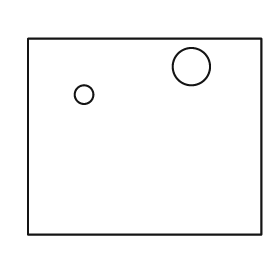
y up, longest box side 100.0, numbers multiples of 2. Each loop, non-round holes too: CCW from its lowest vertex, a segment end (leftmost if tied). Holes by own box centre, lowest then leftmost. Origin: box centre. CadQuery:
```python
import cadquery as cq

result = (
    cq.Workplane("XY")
    .moveTo(-50.0, -42.0)
    .lineTo(50.0, -42.0)
    .lineTo(50.0, 42.0)
    .lineTo(-50.0, 42.0)
    .close()
    .moveTo(-26.0, 18.0)
    .circle(4.0)
    .moveTo(20.0, 30.0)
    .circle(8.0)
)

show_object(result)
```